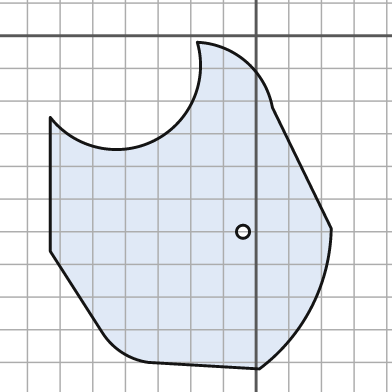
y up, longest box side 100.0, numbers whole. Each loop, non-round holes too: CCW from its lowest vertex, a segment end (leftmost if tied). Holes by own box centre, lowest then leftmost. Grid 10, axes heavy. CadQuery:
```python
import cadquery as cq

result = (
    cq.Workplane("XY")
    .moveTo(1.0, -102.0)
    .threePointArc((17.0, -83.0), (23.0, -59.0))
    .lineTo(5.0, -22.0)
    .threePointArc((-3.0, -8.0), (-18.0, -2.0))
    .threePointArc((-31.0, -32.0), (-63.0, -25.0))
    .lineTo(-63.0, -66.0)
    .lineTo(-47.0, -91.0)
    .threePointArc((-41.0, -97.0), (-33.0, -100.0))
    .close()
    .moveTo(-4.0, -60.0)
    .circle(2.0)
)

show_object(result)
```